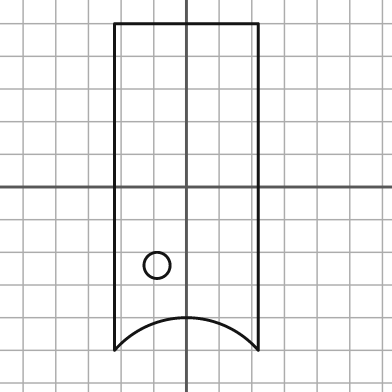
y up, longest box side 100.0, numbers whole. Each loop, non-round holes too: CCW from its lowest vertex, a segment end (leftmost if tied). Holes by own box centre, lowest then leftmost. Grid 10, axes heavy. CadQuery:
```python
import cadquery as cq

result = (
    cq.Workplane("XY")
    .moveTo(-22.0, -50.0)
    .threePointArc((0.0, -40.0), (22.0, -50.0))
    .lineTo(22.0, 50.0)
    .lineTo(-22.0, 50.0)
    .close()
    .moveTo(-9.0, -24.0)
    .circle(4.0)
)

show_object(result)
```